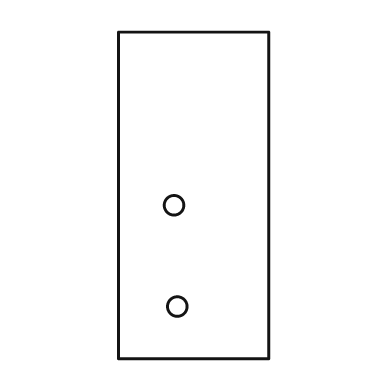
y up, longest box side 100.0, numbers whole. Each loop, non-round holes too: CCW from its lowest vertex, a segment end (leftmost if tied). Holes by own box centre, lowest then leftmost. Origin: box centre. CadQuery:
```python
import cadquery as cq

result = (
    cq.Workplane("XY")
    .moveTo(-23.0, -50.0)
    .lineTo(23.0, -50.0)
    .lineTo(23.0, 50.0)
    .lineTo(-23.0, 50.0)
    .close()
    .moveTo(-5.0, -34.0)
    .circle(3.0)
    .moveTo(-6.0, -3.0)
    .circle(3.0)
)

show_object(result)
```